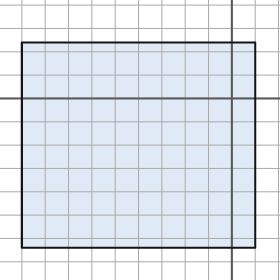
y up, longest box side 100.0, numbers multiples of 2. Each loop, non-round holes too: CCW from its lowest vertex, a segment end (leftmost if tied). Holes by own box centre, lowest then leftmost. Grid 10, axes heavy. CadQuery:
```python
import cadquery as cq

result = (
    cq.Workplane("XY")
    .moveTo(-90.0, -64.0)
    .lineTo(10.0, -64.0)
    .lineTo(10.0, 24.0)
    .lineTo(-90.0, 24.0)
    .close()
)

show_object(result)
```